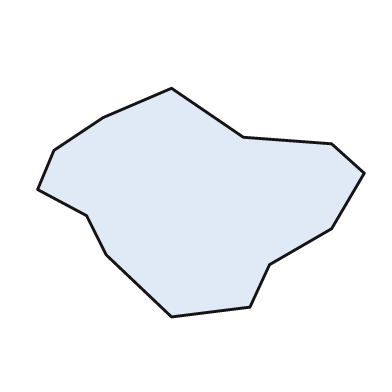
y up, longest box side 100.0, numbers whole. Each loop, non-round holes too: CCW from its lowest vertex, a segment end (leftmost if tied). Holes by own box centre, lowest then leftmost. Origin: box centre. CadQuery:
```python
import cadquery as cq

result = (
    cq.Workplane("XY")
    .moveTo(-9.0, -35.0)
    .lineTo(15.0, -32.0)
    .lineTo(21.0, -19.0)
    .lineTo(40.0, -8.0)
    .lineTo(50.0, 9.0)
    .lineTo(40.0, 18.0)
    .lineTo(13.0, 20.0)
    .lineTo(-9.0, 35.0)
    .lineTo(-30.0, 26.0)
    .lineTo(-45.0, 16.0)
    .lineTo(-50.0, 4.0)
    .lineTo(-35.0, -4.0)
    .lineTo(-29.0, -16.0)
    .close()
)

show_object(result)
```